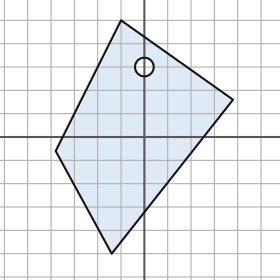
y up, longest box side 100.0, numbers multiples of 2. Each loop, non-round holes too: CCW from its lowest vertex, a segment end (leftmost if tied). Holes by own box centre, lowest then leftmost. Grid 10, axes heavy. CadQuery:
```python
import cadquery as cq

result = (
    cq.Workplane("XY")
    .moveTo(-14.0, -50.0)
    .lineTo(38.0, 16.0)
    .lineTo(-10.0, 50.0)
    .lineTo(-38.0, -6.0)
    .close()
    .moveTo(0.0, 30.0)
    .circle(4.0)
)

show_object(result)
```